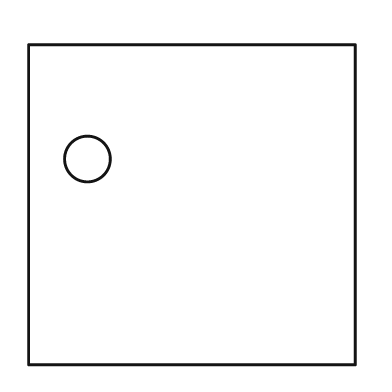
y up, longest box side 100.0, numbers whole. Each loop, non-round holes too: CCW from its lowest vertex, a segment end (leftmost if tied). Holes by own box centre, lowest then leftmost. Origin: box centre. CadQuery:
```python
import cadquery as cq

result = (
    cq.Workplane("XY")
    .moveTo(-50.0, -49.0)
    .lineTo(50.0, -49.0)
    .lineTo(50.0, 49.0)
    .lineTo(-50.0, 49.0)
    .close()
    .moveTo(-32.0, 14.0)
    .circle(7.0)
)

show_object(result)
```